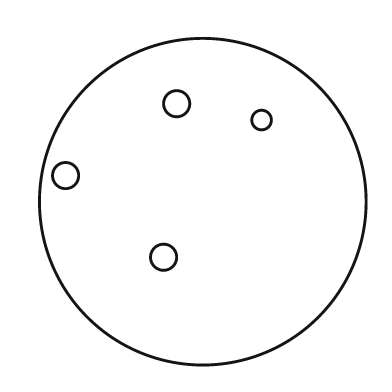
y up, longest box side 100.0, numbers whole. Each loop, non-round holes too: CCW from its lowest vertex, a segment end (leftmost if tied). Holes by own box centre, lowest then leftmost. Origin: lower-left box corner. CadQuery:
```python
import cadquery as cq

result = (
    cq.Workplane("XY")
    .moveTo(50.0, 50.0)
    .circle(50.0)
    .moveTo(38.0, 33.0)
    .circle(4.0)
    .moveTo(8.0, 58.0)
    .circle(4.0)
    .moveTo(68.0, 75.0)
    .circle(3.0)
    .moveTo(42.0, 80.0)
    .circle(4.0)
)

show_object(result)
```